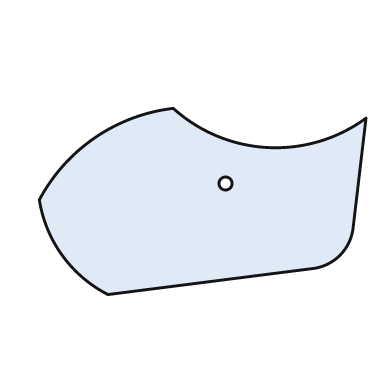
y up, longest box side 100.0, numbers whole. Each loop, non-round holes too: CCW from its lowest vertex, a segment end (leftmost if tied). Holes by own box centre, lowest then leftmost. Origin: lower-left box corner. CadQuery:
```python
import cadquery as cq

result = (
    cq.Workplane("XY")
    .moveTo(21.0, 0.0)
    .lineTo(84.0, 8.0)
    .threePointArc((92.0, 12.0), (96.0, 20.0))
    .lineTo(100.0, 54.0)
    .threePointArc((70.0, 45.0), (41.0, 57.0))
    .threePointArc((17.0, 48.0), (0.0, 29.0))
    .threePointArc((7.0, 12.0), (21.0, 0.0))
    .close()
    .moveTo(57.0, 34.0)
    .circle(2.0)
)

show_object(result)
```